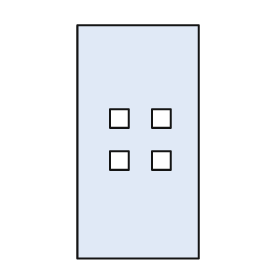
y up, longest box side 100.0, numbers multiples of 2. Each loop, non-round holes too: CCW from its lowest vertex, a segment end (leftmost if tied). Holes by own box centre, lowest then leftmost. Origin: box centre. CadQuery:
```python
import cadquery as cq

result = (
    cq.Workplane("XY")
    .moveTo(-26.0, -50.0)
    .lineTo(26.0, -50.0)
    .lineTo(26.0, 50.0)
    .lineTo(-26.0, 50.0)
    .close()
    .moveTo(-12.0, -12.0)
    .lineTo(-4.0, -12.0)
    .lineTo(-4.0, -4.0)
    .lineTo(-12.0, -4.0)
    .close()
    .moveTo(6.0, -12.0)
    .lineTo(14.0, -12.0)
    .lineTo(14.0, -4.0)
    .lineTo(6.0, -4.0)
    .close()
    .moveTo(-12.0, 6.0)
    .lineTo(-4.0, 6.0)
    .lineTo(-4.0, 14.0)
    .lineTo(-12.0, 14.0)
    .close()
    .moveTo(6.0, 6.0)
    .lineTo(14.0, 6.0)
    .lineTo(14.0, 14.0)
    .lineTo(6.0, 14.0)
    .close()
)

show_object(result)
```